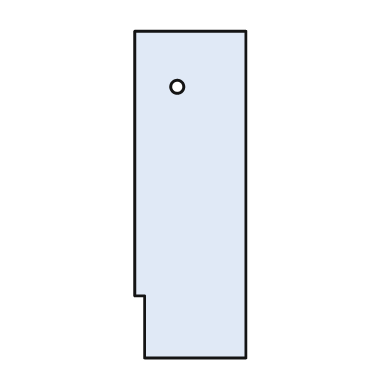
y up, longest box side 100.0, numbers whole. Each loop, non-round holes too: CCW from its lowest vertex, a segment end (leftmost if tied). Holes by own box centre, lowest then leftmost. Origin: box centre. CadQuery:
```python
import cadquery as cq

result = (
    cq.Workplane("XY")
    .moveTo(-14.0, -50.0)
    .lineTo(17.0, -50.0)
    .lineTo(17.0, 50.0)
    .lineTo(-17.0, 50.0)
    .lineTo(-17.0, -31.0)
    .lineTo(-14.0, -31.0)
    .close()
    .moveTo(-4.0, 33.0)
    .circle(2.0)
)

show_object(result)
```